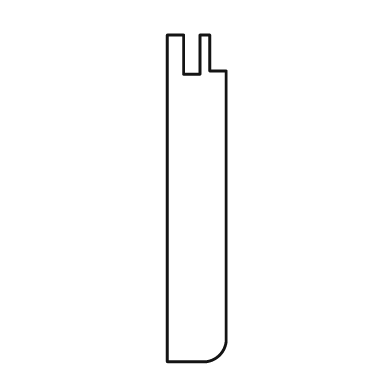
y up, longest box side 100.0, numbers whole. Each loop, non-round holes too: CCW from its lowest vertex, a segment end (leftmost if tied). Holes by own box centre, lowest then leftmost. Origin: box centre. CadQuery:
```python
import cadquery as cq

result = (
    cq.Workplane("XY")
    .moveTo(-9.0, -50.0)
    .lineTo(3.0, -50.0)
    .threePointArc((7.0, -48.0), (9.0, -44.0))
    .lineTo(9.0, 39.0)
    .lineTo(4.0, 39.0)
    .lineTo(4.0, 50.0)
    .lineTo(1.0, 50.0)
    .lineTo(1.0, 38.0)
    .lineTo(-4.0, 38.0)
    .lineTo(-4.0, 50.0)
    .lineTo(-9.0, 50.0)
    .close()
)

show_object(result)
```